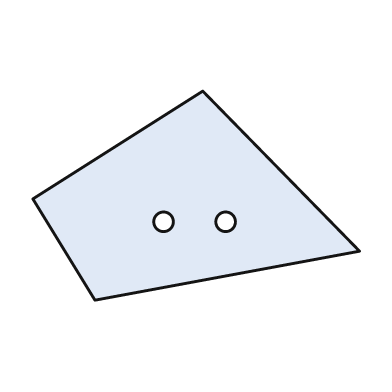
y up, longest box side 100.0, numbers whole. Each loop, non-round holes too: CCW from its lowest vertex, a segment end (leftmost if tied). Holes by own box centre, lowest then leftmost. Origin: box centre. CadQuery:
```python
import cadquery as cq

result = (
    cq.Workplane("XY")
    .moveTo(-31.0, -32.0)
    .lineTo(50.0, -17.0)
    .lineTo(2.0, 32.0)
    .lineTo(-50.0, -1.0)
    .close()
    .moveTo(-10.0, -8.0)
    .circle(3.0)
    .moveTo(9.0, -8.0)
    .circle(3.0)
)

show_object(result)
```